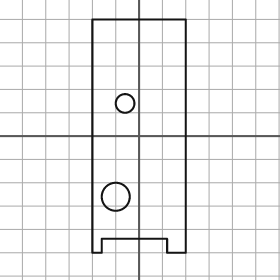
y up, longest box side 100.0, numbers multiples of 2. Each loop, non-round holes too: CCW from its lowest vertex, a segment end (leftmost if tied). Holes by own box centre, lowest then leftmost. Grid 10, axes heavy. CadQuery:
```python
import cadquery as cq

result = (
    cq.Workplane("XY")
    .moveTo(-20.0, -50.0)
    .lineTo(-16.0, -50.0)
    .lineTo(-16.0, -44.0)
    .lineTo(12.0, -44.0)
    .lineTo(12.0, -50.0)
    .lineTo(20.0, -50.0)
    .lineTo(20.0, 50.0)
    .lineTo(-20.0, 50.0)
    .close()
    .moveTo(-10.0, -26.0)
    .circle(6.0)
    .moveTo(-6.0, 14.0)
    .circle(4.0)
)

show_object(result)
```